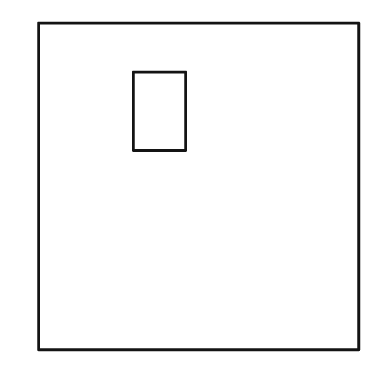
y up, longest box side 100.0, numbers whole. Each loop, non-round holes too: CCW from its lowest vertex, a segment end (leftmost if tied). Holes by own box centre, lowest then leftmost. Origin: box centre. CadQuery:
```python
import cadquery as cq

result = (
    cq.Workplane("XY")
    .moveTo(-49.0, -50.0)
    .lineTo(49.0, -50.0)
    .lineTo(49.0, 50.0)
    .lineTo(-49.0, 50.0)
    .close()
    .moveTo(-20.0, 11.0)
    .lineTo(-4.0, 11.0)
    .lineTo(-4.0, 35.0)
    .lineTo(-20.0, 35.0)
    .close()
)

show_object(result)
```